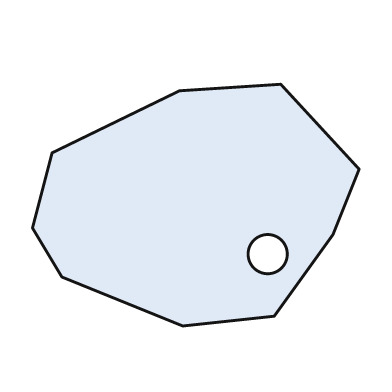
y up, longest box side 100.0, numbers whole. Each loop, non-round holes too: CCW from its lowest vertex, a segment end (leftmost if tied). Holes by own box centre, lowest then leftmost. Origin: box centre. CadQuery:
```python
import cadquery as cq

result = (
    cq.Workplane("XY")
    .moveTo(-4.0, -37.0)
    .lineTo(24.0, -34.0)
    .lineTo(42.0, -9.0)
    .lineTo(50.0, 11.0)
    .lineTo(26.0, 37.0)
    .lineTo(-5.0, 35.0)
    .lineTo(-44.0, 16.0)
    .lineTo(-50.0, -7.0)
    .lineTo(-41.0, -22.0)
    .close()
    .moveTo(22.0, -15.0)
    .circle(6.0)
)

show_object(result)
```